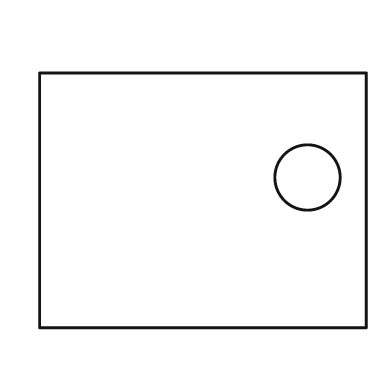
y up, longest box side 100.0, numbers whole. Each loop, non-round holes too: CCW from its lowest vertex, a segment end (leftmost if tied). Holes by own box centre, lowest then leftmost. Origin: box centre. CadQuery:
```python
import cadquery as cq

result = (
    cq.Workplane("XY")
    .moveTo(-50.0, -39.0)
    .lineTo(50.0, -39.0)
    .lineTo(50.0, 39.0)
    .lineTo(-50.0, 39.0)
    .close()
    .moveTo(32.0, 7.0)
    .circle(10.0)
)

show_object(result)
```